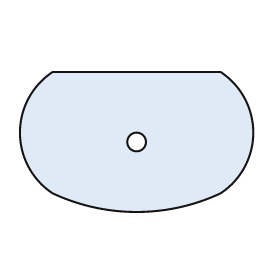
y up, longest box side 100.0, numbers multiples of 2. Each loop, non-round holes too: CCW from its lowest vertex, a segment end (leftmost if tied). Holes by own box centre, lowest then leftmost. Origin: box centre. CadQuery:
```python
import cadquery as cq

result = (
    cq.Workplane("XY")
    .moveTo(-36.0, -22.0)
    .threePointArc((0.0, -30.0), (36.0, -22.0))
    .threePointArc((50.0, 4.0), (36.0, 30.0))
    .lineTo(-36.0, 30.0)
    .threePointArc((-50.0, 4.0), (-36.0, -22.0))
    .close()
    .moveTo(0.0, 0.0)
    .circle(4.0)
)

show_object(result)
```